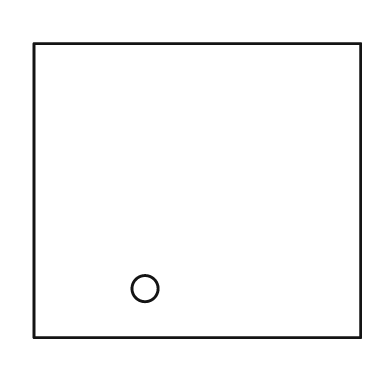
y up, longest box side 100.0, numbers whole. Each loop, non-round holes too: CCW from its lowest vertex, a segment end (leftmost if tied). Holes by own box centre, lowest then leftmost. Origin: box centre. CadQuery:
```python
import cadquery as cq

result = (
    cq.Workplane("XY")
    .moveTo(-50.0, -45.0)
    .lineTo(50.0, -45.0)
    .lineTo(50.0, 45.0)
    .lineTo(-50.0, 45.0)
    .close()
    .moveTo(-16.0, -30.0)
    .circle(4.0)
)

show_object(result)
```